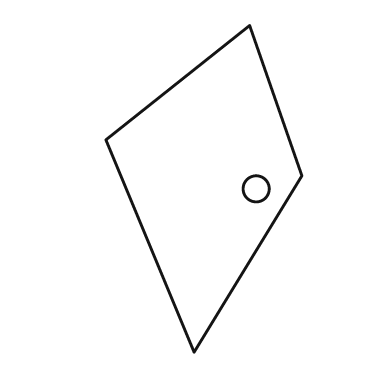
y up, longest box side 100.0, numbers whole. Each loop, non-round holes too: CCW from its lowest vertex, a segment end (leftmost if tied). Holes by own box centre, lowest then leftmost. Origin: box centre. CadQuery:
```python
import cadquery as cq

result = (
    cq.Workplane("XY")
    .moveTo(-3.0, -50.0)
    .lineTo(30.0, 4.0)
    .lineTo(14.0, 50.0)
    .lineTo(-30.0, 15.0)
    .close()
    .moveTo(16.0, 0.0)
    .circle(4.0)
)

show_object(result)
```